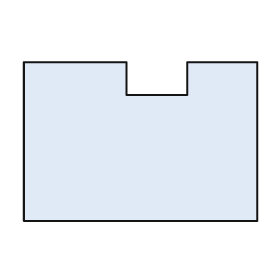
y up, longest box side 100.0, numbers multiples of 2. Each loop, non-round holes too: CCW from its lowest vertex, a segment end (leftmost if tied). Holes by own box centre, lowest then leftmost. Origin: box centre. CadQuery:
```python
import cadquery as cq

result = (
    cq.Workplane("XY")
    .moveTo(-50.0, -34.0)
    .lineTo(50.0, -34.0)
    .lineTo(50.0, 34.0)
    .lineTo(20.0, 34.0)
    .lineTo(20.0, 20.0)
    .lineTo(-6.0, 20.0)
    .lineTo(-6.0, 34.0)
    .lineTo(-50.0, 34.0)
    .close()
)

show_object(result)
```